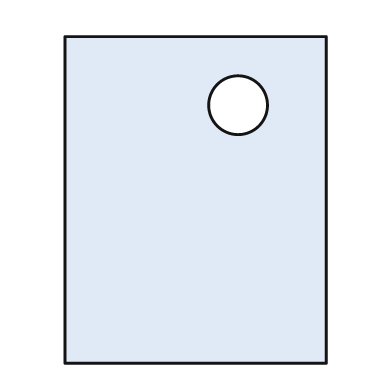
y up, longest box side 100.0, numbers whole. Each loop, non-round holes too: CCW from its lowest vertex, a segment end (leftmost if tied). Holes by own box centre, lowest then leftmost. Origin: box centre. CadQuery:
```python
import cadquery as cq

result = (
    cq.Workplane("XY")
    .moveTo(-40.0, -50.0)
    .lineTo(40.0, -50.0)
    .lineTo(40.0, 50.0)
    .lineTo(-40.0, 50.0)
    .close()
    .moveTo(13.0, 29.0)
    .circle(9.0)
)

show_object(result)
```